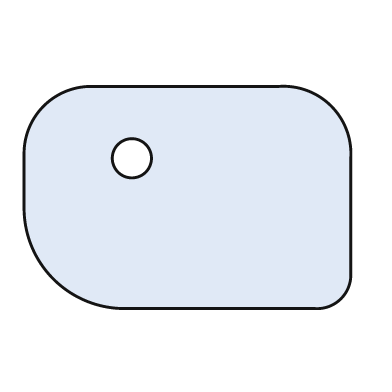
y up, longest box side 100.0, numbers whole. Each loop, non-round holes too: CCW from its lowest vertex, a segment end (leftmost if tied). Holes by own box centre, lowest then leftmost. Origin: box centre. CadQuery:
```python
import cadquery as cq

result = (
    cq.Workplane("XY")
    .moveTo(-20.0, -34.0)
    .lineTo(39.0, -34.0)
    .threePointArc((47.0, -31.0), (50.0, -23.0))
    .lineTo(50.0, 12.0)
    .threePointArc((44.0, 28.0), (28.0, 34.0))
    .lineTo(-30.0, 34.0)
    .threePointArc((-44.0, 28.0), (-50.0, 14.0))
    .lineTo(-50.0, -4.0)
    .threePointArc((-41.0, -25.0), (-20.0, -34.0))
    .close()
    .moveTo(-17.0, 12.0)
    .circle(6.0)
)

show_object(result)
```